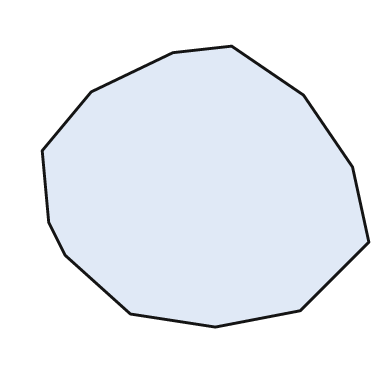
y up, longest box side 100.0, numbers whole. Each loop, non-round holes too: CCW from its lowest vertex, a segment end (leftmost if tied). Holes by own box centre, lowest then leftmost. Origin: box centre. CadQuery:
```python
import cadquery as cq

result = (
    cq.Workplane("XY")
    .moveTo(3.0, -43.0)
    .lineTo(29.0, -38.0)
    .lineTo(50.0, -17.0)
    .lineTo(45.0, 6.0)
    .lineTo(30.0, 28.0)
    .lineTo(8.0, 43.0)
    .lineTo(-10.0, 41.0)
    .lineTo(-35.0, 29.0)
    .lineTo(-50.0, 11.0)
    .lineTo(-48.0, -11.0)
    .lineTo(-43.0, -21.0)
    .lineTo(-23.0, -39.0)
    .close()
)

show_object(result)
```